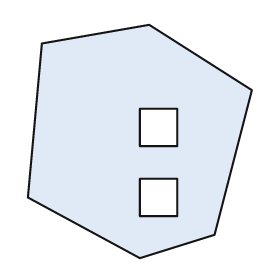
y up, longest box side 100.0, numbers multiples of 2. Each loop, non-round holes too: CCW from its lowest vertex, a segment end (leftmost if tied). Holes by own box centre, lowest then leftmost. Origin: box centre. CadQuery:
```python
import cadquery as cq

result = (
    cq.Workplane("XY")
    .moveTo(0.0, -50.0)
    .lineTo(32.0, -40.0)
    .lineTo(48.0, 22.0)
    .lineTo(4.0, 50.0)
    .lineTo(-42.0, 42.0)
    .lineTo(-48.0, -24.0)
    .close()
    .moveTo(0.0, -32.0)
    .lineTo(16.0, -32.0)
    .lineTo(16.0, -16.0)
    .lineTo(0.0, -16.0)
    .close()
    .moveTo(0.0, -2.0)
    .lineTo(16.0, -2.0)
    .lineTo(16.0, 14.0)
    .lineTo(0.0, 14.0)
    .close()
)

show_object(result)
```